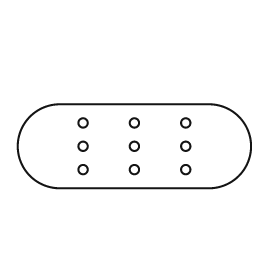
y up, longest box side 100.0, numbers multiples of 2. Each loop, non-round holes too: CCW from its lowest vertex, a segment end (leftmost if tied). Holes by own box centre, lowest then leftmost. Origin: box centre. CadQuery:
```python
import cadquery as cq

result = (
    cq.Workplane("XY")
    .moveTo(-32.0, -18.0)
    .lineTo(32.0, -18.0)
    .threePointArc((50.0, 0.0), (32.0, 18.0))
    .lineTo(-32.0, 18.0)
    .threePointArc((-50.0, 0.0), (-32.0, -18.0))
    .close()
    .moveTo(-22.0, -10.0)
    .circle(2.0)
    .moveTo(0.0, -10.0)
    .circle(2.0)
    .moveTo(22.0, -10.0)
    .circle(2.0)
    .moveTo(-22.0, 0.0)
    .circle(2.0)
    .moveTo(0.0, 0.0)
    .circle(2.0)
    .moveTo(22.0, 0.0)
    .circle(2.0)
    .moveTo(-22.0, 10.0)
    .circle(2.0)
    .moveTo(0.0, 10.0)
    .circle(2.0)
    .moveTo(22.0, 10.0)
    .circle(2.0)
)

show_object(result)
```